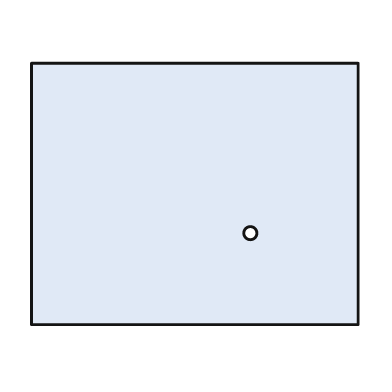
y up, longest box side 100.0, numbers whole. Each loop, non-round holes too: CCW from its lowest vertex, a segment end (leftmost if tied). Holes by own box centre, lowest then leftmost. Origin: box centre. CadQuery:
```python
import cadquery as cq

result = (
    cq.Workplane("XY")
    .moveTo(-50.0, -40.0)
    .lineTo(50.0, -40.0)
    .lineTo(50.0, 40.0)
    .lineTo(-50.0, 40.0)
    .close()
    .moveTo(17.0, -12.0)
    .circle(2.0)
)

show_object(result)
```